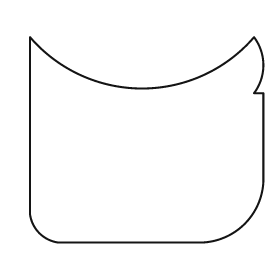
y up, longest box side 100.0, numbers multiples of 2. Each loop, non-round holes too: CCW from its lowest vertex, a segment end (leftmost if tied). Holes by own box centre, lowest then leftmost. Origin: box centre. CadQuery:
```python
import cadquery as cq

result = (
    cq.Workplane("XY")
    .moveTo(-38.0, -44.0)
    .lineTo(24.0, -44.0)
    .threePointArc((42.0, -36.0), (50.0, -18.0))
    .lineTo(50.0, 20.0)
    .lineTo(46.0, 20.0)
    .threePointArc((50.0, 32.0), (46.0, 44.0))
    .threePointArc((-2.0, 22.0), (-50.0, 44.0))
    .lineTo(-50.0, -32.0)
    .threePointArc((-46.0, -40.0), (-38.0, -44.0))
    .close()
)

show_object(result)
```